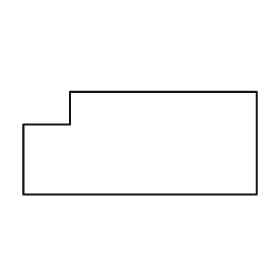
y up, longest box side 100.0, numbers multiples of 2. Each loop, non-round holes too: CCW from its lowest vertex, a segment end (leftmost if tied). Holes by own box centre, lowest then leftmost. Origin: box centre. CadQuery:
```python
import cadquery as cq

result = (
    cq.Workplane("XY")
    .moveTo(-50.0, -22.0)
    .lineTo(50.0, -22.0)
    .lineTo(50.0, 22.0)
    .lineTo(-30.0, 22.0)
    .lineTo(-30.0, 8.0)
    .lineTo(-50.0, 8.0)
    .close()
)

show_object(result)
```